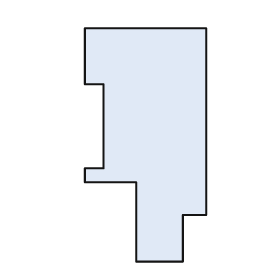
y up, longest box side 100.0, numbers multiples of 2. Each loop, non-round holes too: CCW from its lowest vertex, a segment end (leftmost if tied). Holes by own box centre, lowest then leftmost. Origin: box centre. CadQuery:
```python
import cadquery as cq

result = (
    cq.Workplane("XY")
    .moveTo(-4.0, -50.0)
    .lineTo(16.0, -50.0)
    .lineTo(16.0, -30.0)
    .lineTo(26.0, -30.0)
    .lineTo(26.0, 50.0)
    .lineTo(-26.0, 50.0)
    .lineTo(-26.0, 26.0)
    .lineTo(-18.0, 26.0)
    .lineTo(-18.0, -10.0)
    .lineTo(-26.0, -10.0)
    .lineTo(-26.0, -16.0)
    .lineTo(-4.0, -16.0)
    .close()
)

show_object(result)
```